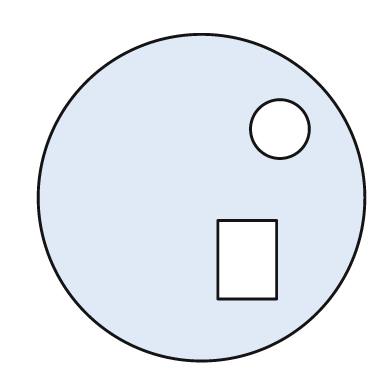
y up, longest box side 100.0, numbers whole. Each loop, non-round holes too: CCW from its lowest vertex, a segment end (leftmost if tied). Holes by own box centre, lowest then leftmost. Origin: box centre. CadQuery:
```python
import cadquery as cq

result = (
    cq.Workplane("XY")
    .moveTo(0.0, 0.0)
    .circle(50.0)
    .moveTo(5.0, -31.0)
    .lineTo(23.0, -31.0)
    .lineTo(23.0, -7.0)
    .lineTo(5.0, -7.0)
    .close()
    .moveTo(24.0, 21.0)
    .circle(9.0)
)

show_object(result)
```